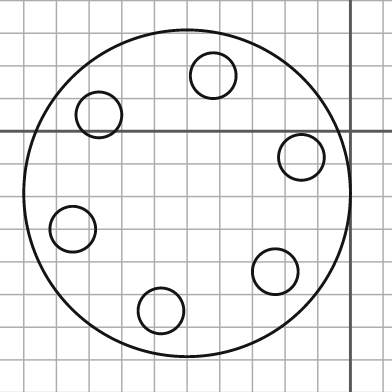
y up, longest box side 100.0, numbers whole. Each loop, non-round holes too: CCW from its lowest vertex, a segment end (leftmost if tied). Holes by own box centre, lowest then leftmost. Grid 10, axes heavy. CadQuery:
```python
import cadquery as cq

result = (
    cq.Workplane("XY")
    .moveTo(-50.0, -19.0)
    .circle(50.0)
    .moveTo(-58.0, -55.0)
    .circle(7.0)
    .moveTo(-23.0, -43.0)
    .circle(7.0)
    .moveTo(-85.0, -30.0)
    .circle(7.0)
    .moveTo(-15.0, -8.0)
    .circle(7.0)
    .moveTo(-77.0, 5.0)
    .circle(7.0)
    .moveTo(-42.0, 17.0)
    .circle(7.0)
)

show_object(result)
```